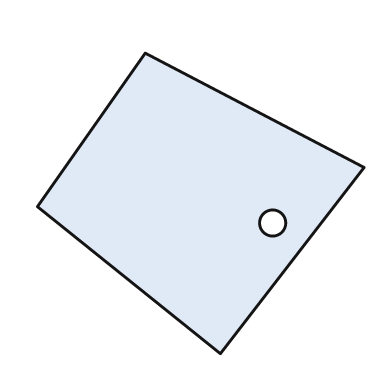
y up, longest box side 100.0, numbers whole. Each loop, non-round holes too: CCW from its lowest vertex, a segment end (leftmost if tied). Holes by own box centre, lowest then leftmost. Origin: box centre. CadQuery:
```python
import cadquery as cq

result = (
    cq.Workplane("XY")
    .moveTo(6.0, -46.0)
    .lineTo(50.0, 11.0)
    .lineTo(-17.0, 46.0)
    .lineTo(-50.0, -1.0)
    .close()
    .moveTo(22.0, -6.0)
    .circle(4.0)
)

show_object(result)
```